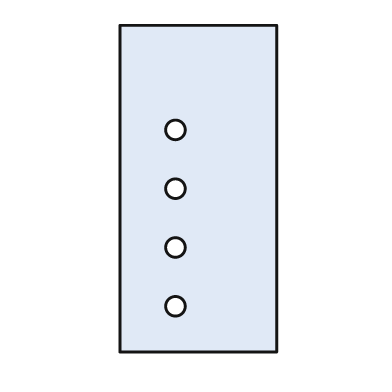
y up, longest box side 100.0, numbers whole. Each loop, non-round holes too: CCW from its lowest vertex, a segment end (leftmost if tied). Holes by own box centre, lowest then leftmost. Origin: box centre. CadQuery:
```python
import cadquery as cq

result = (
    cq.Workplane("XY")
    .moveTo(-24.0, -50.0)
    .lineTo(24.0, -50.0)
    .lineTo(24.0, 50.0)
    .lineTo(-24.0, 50.0)
    .close()
    .moveTo(-7.0, -36.0)
    .circle(3.0)
    .moveTo(-7.0, -18.0)
    .circle(3.0)
    .moveTo(-7.0, 0.0)
    .circle(3.0)
    .moveTo(-7.0, 18.0)
    .circle(3.0)
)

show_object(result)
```